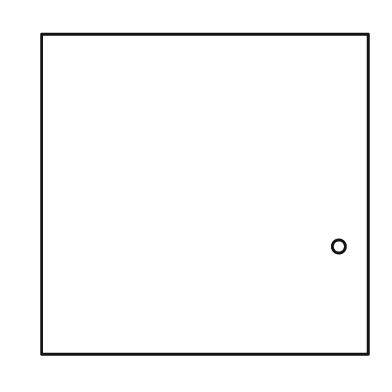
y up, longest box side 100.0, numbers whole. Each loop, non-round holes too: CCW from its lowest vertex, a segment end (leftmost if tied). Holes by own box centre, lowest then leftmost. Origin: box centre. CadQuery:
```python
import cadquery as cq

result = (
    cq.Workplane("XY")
    .moveTo(-50.0, -49.0)
    .lineTo(50.0, -49.0)
    .lineTo(50.0, 49.0)
    .lineTo(-50.0, 49.0)
    .close()
    .moveTo(41.0, -16.0)
    .circle(2.0)
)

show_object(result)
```